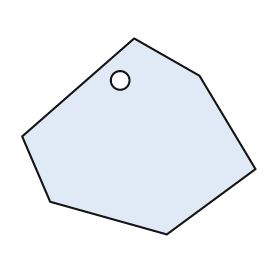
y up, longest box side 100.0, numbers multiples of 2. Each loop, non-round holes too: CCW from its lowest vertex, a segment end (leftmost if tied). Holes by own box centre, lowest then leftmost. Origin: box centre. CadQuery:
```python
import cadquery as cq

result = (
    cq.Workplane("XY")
    .moveTo(12.0, -42.0)
    .lineTo(50.0, -14.0)
    .lineTo(26.0, 26.0)
    .lineTo(-2.0, 42.0)
    .lineTo(-50.0, 0.0)
    .lineTo(-38.0, -28.0)
    .close()
    .moveTo(-8.0, 24.0)
    .circle(4.0)
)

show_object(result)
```